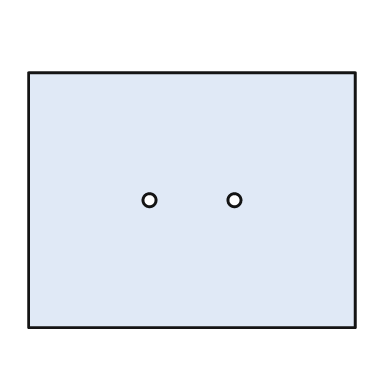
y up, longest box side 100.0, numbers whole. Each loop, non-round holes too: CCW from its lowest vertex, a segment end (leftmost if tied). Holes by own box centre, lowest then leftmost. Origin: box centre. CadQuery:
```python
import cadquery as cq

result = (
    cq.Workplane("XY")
    .moveTo(-50.0, -39.0)
    .lineTo(50.0, -39.0)
    .lineTo(50.0, 39.0)
    .lineTo(-50.0, 39.0)
    .close()
    .moveTo(-13.0, 0.0)
    .circle(2.0)
    .moveTo(13.0, 0.0)
    .circle(2.0)
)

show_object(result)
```